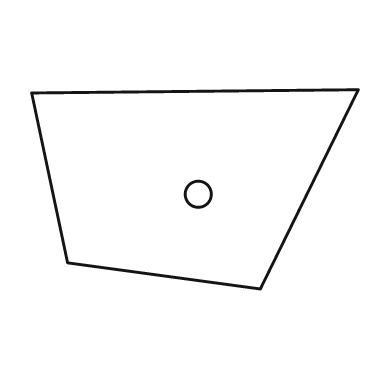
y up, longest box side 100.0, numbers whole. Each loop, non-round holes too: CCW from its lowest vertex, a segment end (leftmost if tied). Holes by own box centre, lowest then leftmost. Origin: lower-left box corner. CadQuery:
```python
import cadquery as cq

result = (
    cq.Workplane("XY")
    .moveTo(70.0, 0.0)
    .lineTo(100.0, 61.0)
    .lineTo(0.0, 60.0)
    .lineTo(11.0, 8.0)
    .close()
    .moveTo(51.0, 29.0)
    .circle(4.0)
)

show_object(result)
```